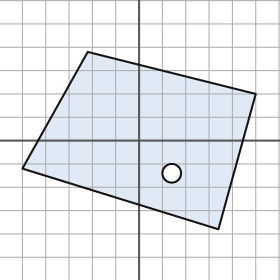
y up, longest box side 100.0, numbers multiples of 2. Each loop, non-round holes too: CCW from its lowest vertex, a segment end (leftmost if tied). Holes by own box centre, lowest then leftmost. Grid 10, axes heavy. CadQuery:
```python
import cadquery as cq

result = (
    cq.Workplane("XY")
    .moveTo(34.0, -38.0)
    .lineTo(50.0, 20.0)
    .lineTo(-22.0, 38.0)
    .lineTo(-50.0, -12.0)
    .close()
    .moveTo(14.0, -14.0)
    .circle(4.0)
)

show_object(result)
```